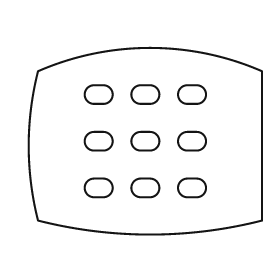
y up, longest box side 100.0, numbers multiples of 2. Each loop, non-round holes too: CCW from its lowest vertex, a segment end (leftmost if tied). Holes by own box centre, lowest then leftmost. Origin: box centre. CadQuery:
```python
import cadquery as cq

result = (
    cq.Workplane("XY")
    .moveTo(-46.0, -34.0)
    .threePointArc((2.0, -40.0), (50.0, -34.0))
    .lineTo(50.0, 30.0)
    .threePointArc((2.0, 40.0), (-46.0, 30.0))
    .threePointArc((-50.0, -2.0), (-46.0, -34.0))
    .close()
    .moveTo(-22.0, -24.0)
    .lineTo(-18.0, -24.0)
    .threePointArc((-14.0, -20.0), (-18.0, -16.0))
    .lineTo(-22.0, -16.0)
    .threePointArc((-26.0, -20.0), (-22.0, -24.0))
    .close()
    .moveTo(-2.0, -24.0)
    .lineTo(2.0, -24.0)
    .threePointArc((6.0, -20.0), (2.0, -16.0))
    .lineTo(-2.0, -16.0)
    .threePointArc((-6.0, -20.0), (-2.0, -24.0))
    .close()
    .moveTo(18.0, -24.0)
    .lineTo(22.0, -24.0)
    .threePointArc((26.0, -20.0), (22.0, -16.0))
    .lineTo(18.0, -16.0)
    .threePointArc((14.0, -20.0), (18.0, -24.0))
    .close()
    .moveTo(-22.0, -4.0)
    .lineTo(-18.0, -4.0)
    .threePointArc((-14.0, 0.0), (-18.0, 4.0))
    .lineTo(-22.0, 4.0)
    .threePointArc((-26.0, 0.0), (-22.0, -4.0))
    .close()
    .moveTo(-2.0, -4.0)
    .lineTo(2.0, -4.0)
    .threePointArc((6.0, 0.0), (2.0, 4.0))
    .lineTo(-2.0, 4.0)
    .threePointArc((-6.0, 0.0), (-2.0, -4.0))
    .close()
    .moveTo(18.0, -4.0)
    .lineTo(22.0, -4.0)
    .threePointArc((26.0, 0.0), (22.0, 4.0))
    .lineTo(18.0, 4.0)
    .threePointArc((14.0, 0.0), (18.0, -4.0))
    .close()
    .moveTo(-22.0, 16.0)
    .lineTo(-18.0, 16.0)
    .threePointArc((-14.0, 20.0), (-18.0, 24.0))
    .lineTo(-22.0, 24.0)
    .threePointArc((-26.0, 20.0), (-22.0, 16.0))
    .close()
    .moveTo(-2.0, 16.0)
    .lineTo(2.0, 16.0)
    .threePointArc((6.0, 20.0), (2.0, 24.0))
    .lineTo(-2.0, 24.0)
    .threePointArc((-6.0, 20.0), (-2.0, 16.0))
    .close()
    .moveTo(18.0, 16.0)
    .lineTo(22.0, 16.0)
    .threePointArc((26.0, 20.0), (22.0, 24.0))
    .lineTo(18.0, 24.0)
    .threePointArc((14.0, 20.0), (18.0, 16.0))
    .close()
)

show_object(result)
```